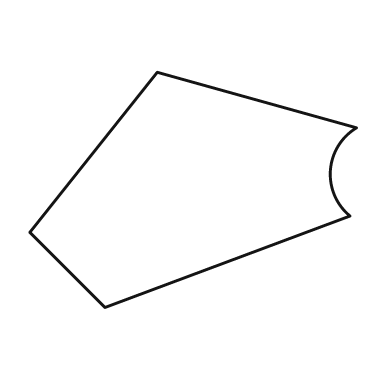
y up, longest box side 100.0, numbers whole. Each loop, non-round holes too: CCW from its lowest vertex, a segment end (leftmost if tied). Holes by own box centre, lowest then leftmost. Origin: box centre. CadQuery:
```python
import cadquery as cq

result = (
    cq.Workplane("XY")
    .moveTo(-27.0, -36.0)
    .lineTo(48.0, -8.0)
    .threePointArc((42.0, 6.0), (50.0, 19.0))
    .lineTo(-11.0, 36.0)
    .lineTo(-50.0, -13.0)
    .close()
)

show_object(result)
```